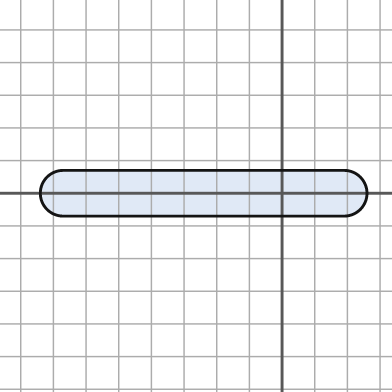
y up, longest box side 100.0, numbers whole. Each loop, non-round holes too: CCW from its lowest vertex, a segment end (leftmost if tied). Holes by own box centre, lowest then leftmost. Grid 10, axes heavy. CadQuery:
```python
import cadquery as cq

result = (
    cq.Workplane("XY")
    .moveTo(-67.0, -7.0)
    .lineTo(19.0, -7.0)
    .threePointArc((26.0, 0.0), (19.0, 7.0))
    .lineTo(-67.0, 7.0)
    .threePointArc((-74.0, 0.0), (-67.0, -7.0))
    .close()
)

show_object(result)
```